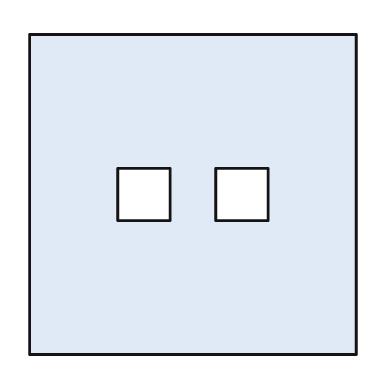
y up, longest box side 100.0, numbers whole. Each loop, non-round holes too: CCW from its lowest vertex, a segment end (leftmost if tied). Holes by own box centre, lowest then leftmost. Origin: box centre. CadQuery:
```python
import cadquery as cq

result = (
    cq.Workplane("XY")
    .moveTo(-50.0, -49.0)
    .lineTo(50.0, -49.0)
    .lineTo(50.0, 49.0)
    .lineTo(-50.0, 49.0)
    .close()
    .moveTo(-23.0, -8.0)
    .lineTo(-7.0, -8.0)
    .lineTo(-7.0, 8.0)
    .lineTo(-23.0, 8.0)
    .close()
    .moveTo(7.0, -8.0)
    .lineTo(23.0, -8.0)
    .lineTo(23.0, 8.0)
    .lineTo(7.0, 8.0)
    .close()
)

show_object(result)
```